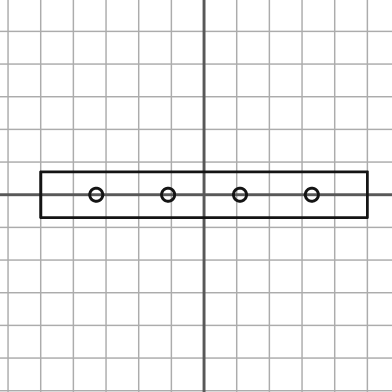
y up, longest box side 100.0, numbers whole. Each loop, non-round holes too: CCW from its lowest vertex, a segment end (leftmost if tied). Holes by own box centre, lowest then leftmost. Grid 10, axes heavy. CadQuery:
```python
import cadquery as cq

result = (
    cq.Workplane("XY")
    .moveTo(-50.0, -7.0)
    .lineTo(50.0, -7.0)
    .lineTo(50.0, 7.0)
    .lineTo(-50.0, 7.0)
    .close()
    .moveTo(-33.0, 0.0)
    .circle(2.0)
    .moveTo(-11.0, 0.0)
    .circle(2.0)
    .moveTo(11.0, 0.0)
    .circle(2.0)
    .moveTo(33.0, 0.0)
    .circle(2.0)
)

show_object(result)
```